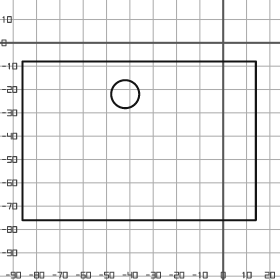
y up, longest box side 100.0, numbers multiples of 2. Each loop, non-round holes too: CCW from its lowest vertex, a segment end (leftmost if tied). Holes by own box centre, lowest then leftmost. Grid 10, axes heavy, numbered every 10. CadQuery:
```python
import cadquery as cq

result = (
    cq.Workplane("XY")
    .moveTo(-86.0, -76.0)
    .lineTo(14.0, -76.0)
    .lineTo(14.0, -8.0)
    .lineTo(-86.0, -8.0)
    .close()
    .moveTo(-42.0, -22.0)
    .circle(6.0)
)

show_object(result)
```